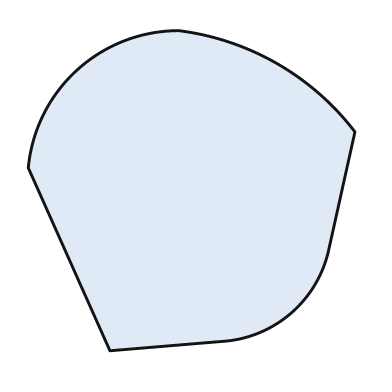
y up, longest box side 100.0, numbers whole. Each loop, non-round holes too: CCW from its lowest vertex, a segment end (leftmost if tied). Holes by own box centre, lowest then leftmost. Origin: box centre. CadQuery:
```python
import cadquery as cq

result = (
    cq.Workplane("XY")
    .moveTo(-25.0, -49.0)
    .lineTo(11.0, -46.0)
    .threePointArc((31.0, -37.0), (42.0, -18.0))
    .lineTo(50.0, 18.0)
    .threePointArc((26.0, 39.0), (-4.0, 49.0))
    .threePointArc((-35.0, 37.0), (-50.0, 7.0))
    .close()
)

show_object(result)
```